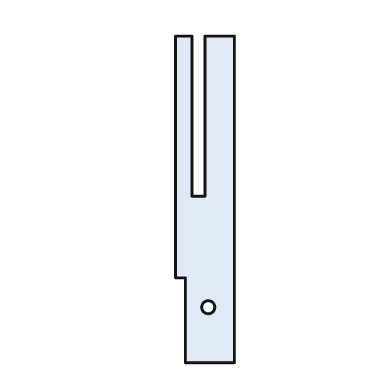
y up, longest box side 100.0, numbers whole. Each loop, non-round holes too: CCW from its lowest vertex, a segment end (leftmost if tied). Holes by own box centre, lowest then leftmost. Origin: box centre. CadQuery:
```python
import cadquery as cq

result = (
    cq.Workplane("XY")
    .moveTo(-6.0, -50.0)
    .lineTo(9.0, -50.0)
    .lineTo(9.0, 50.0)
    .lineTo(0.0, 50.0)
    .lineTo(0.0, 1.0)
    .lineTo(-4.0, 1.0)
    .lineTo(-4.0, 50.0)
    .lineTo(-9.0, 50.0)
    .lineTo(-9.0, -24.0)
    .lineTo(-6.0, -24.0)
    .close()
    .moveTo(1.0, -33.0)
    .circle(2.0)
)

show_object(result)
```